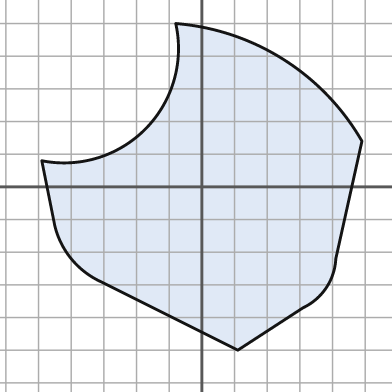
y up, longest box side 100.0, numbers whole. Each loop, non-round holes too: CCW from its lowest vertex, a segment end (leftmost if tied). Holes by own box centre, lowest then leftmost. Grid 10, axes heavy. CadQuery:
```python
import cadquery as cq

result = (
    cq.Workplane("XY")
    .moveTo(11.0, -50.0)
    .lineTo(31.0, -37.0)
    .threePointArc((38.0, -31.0), (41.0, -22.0))
    .lineTo(49.0, 14.0)
    .threePointArc((25.0, 39.0), (-8.0, 50.0))
    .threePointArc((-17.0, 18.0), (-49.0, 8.0))
    .lineTo(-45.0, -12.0)
    .threePointArc((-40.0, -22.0), (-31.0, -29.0))
    .close()
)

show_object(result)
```